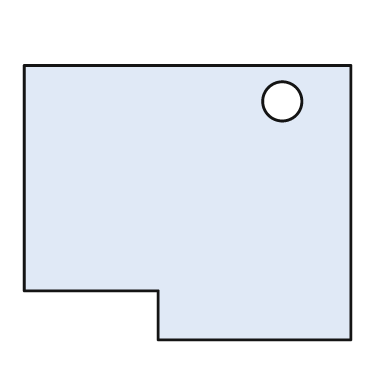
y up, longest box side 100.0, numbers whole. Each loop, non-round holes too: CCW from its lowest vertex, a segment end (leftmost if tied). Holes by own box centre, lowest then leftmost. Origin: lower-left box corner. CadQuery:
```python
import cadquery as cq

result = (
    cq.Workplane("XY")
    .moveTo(41.0, 0.0)
    .lineTo(100.0, 0.0)
    .lineTo(100.0, 84.0)
    .lineTo(0.0, 84.0)
    .lineTo(0.0, 15.0)
    .lineTo(41.0, 15.0)
    .close()
    .moveTo(79.0, 73.0)
    .circle(6.0)
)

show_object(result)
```